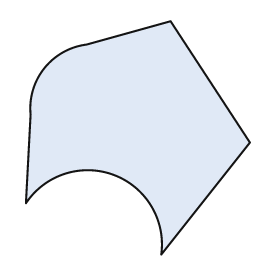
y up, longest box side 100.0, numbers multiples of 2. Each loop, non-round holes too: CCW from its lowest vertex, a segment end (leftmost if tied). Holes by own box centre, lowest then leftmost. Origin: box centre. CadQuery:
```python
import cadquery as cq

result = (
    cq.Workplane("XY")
    .moveTo(10.0, -50.0)
    .lineTo(48.0, -2.0)
    .lineTo(14.0, 50.0)
    .lineTo(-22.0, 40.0)
    .threePointArc((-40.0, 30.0), (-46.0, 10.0))
    .lineTo(-48.0, -28.0)
    .threePointArc((-10.0, -16.0), (10.0, -50.0))
    .close()
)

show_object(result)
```